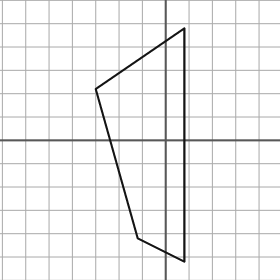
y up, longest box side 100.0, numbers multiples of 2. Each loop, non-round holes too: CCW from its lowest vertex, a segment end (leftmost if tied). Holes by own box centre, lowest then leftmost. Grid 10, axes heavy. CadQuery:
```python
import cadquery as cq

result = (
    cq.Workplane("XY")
    .moveTo(8.0, -52.0)
    .lineTo(8.0, 48.0)
    .lineTo(-30.0, 22.0)
    .lineTo(-12.0, -42.0)
    .close()
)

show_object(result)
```